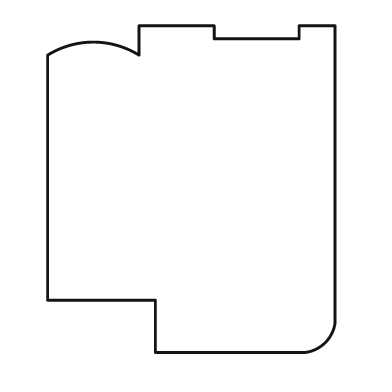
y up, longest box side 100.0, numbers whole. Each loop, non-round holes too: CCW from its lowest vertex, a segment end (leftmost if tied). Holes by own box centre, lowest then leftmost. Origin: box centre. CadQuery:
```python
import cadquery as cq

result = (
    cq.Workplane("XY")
    .moveTo(-11.0, -50.0)
    .lineTo(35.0, -50.0)
    .threePointArc((41.0, -47.0), (44.0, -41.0))
    .lineTo(44.0, 50.0)
    .lineTo(33.0, 50.0)
    .lineTo(33.0, 46.0)
    .lineTo(7.0, 46.0)
    .lineTo(7.0, 50.0)
    .lineTo(-16.0, 50.0)
    .lineTo(-16.0, 41.0)
    .threePointArc((-30.0, 45.0), (-44.0, 41.0))
    .lineTo(-44.0, -34.0)
    .lineTo(-11.0, -34.0)
    .close()
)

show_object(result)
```